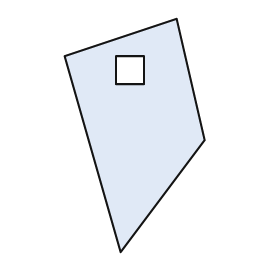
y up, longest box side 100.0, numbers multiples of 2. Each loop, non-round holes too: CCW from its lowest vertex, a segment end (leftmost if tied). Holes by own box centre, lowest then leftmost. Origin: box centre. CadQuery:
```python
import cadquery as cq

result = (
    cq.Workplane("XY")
    .moveTo(-6.0, -50.0)
    .lineTo(30.0, -2.0)
    .lineTo(18.0, 50.0)
    .lineTo(-30.0, 34.0)
    .close()
    .moveTo(-8.0, 22.0)
    .lineTo(4.0, 22.0)
    .lineTo(4.0, 34.0)
    .lineTo(-8.0, 34.0)
    .close()
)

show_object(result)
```